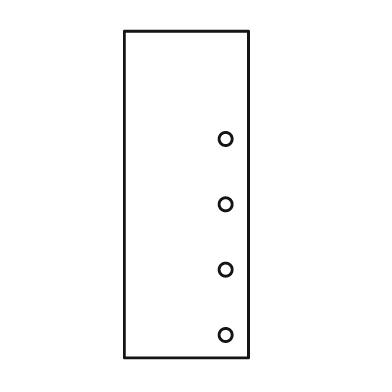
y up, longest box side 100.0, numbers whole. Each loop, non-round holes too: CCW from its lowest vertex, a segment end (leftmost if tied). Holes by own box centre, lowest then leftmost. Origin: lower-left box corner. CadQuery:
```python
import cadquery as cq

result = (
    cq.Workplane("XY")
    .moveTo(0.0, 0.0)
    .lineTo(38.0, 0.0)
    .lineTo(38.0, 100.0)
    .lineTo(0.0, 100.0)
    .close()
    .moveTo(31.0, 7.0)
    .circle(2.0)
    .moveTo(31.0, 27.0)
    .circle(2.0)
    .moveTo(31.0, 47.0)
    .circle(2.0)
    .moveTo(31.0, 67.0)
    .circle(2.0)
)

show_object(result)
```